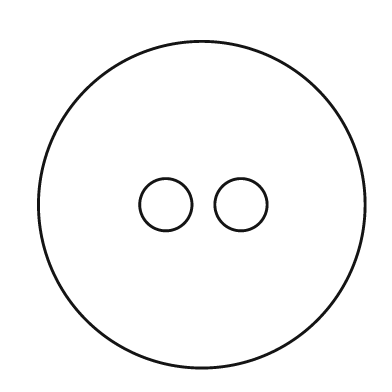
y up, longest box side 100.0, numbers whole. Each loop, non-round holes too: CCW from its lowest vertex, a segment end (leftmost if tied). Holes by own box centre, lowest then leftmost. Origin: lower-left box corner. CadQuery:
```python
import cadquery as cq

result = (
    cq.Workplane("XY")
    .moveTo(50.0, 50.0)
    .circle(50.0)
    .moveTo(39.0, 50.0)
    .circle(8.0)
    .moveTo(62.0, 50.0)
    .circle(8.0)
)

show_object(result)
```